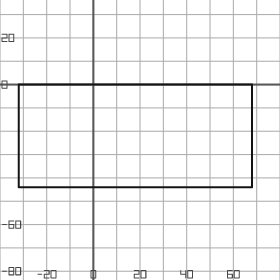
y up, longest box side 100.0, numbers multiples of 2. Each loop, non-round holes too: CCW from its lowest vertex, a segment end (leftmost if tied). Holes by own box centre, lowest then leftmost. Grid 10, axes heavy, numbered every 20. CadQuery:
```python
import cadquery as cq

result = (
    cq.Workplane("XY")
    .moveTo(-32.0, -44.0)
    .lineTo(68.0, -44.0)
    .lineTo(68.0, 0.0)
    .lineTo(-32.0, 0.0)
    .close()
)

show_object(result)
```